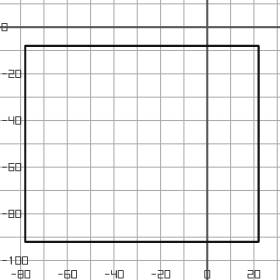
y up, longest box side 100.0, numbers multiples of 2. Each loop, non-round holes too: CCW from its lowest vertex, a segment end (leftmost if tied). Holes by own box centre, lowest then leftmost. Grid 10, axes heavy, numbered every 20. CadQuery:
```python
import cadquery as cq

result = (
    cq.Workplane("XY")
    .moveTo(-78.0, -92.0)
    .lineTo(22.0, -92.0)
    .lineTo(22.0, -8.0)
    .lineTo(-78.0, -8.0)
    .close()
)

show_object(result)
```